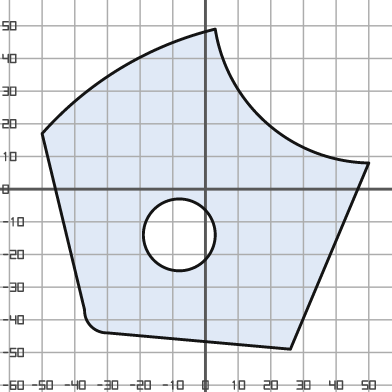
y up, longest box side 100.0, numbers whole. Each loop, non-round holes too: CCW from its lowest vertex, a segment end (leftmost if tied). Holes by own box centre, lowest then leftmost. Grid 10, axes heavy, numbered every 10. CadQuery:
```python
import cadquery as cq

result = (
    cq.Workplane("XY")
    .moveTo(26.0, -49.0)
    .lineTo(50.0, 8.0)
    .threePointArc((19.0, 20.0), (3.0, 49.0))
    .threePointArc((-26.0, 37.0), (-50.0, 17.0))
    .lineTo(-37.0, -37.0)
    .threePointArc((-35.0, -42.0), (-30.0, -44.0))
    .close()
    .moveTo(-8.0, -14.0)
    .circle(11.0)
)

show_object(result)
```